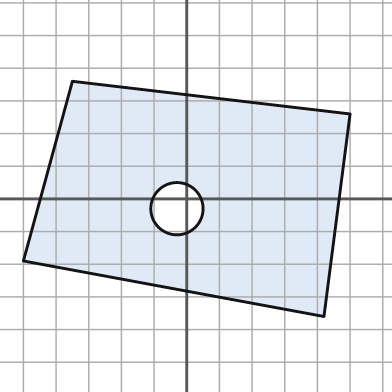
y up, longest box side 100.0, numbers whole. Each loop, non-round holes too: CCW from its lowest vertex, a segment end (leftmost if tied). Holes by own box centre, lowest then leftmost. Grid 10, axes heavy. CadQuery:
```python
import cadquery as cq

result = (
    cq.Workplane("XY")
    .moveTo(42.0, -36.0)
    .lineTo(50.0, 26.0)
    .lineTo(-35.0, 36.0)
    .lineTo(-50.0, -19.0)
    .close()
    .moveTo(-3.0, -3.0)
    .circle(8.0)
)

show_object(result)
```